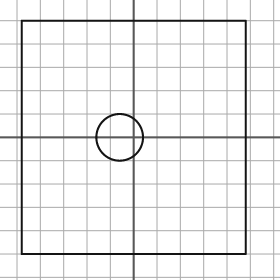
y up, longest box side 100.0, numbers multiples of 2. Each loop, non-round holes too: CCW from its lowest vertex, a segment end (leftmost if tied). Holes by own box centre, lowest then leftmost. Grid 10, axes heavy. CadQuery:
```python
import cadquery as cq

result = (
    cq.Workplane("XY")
    .moveTo(-48.0, -50.0)
    .lineTo(48.0, -50.0)
    .lineTo(48.0, 50.0)
    .lineTo(-48.0, 50.0)
    .close()
    .moveTo(-6.0, 0.0)
    .circle(10.0)
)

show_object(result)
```